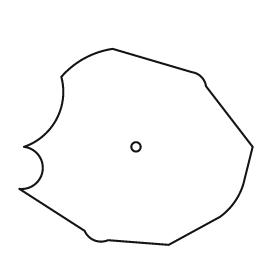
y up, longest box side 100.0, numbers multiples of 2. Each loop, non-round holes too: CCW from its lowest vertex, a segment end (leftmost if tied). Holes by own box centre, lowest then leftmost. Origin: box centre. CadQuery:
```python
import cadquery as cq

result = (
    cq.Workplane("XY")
    .moveTo(14.0, -42.0)
    .lineTo(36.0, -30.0)
    .threePointArc((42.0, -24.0), (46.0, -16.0))
    .lineTo(50.0, 0.0)
    .lineTo(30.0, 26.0)
    .threePointArc((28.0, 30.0), (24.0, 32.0))
    .lineTo(-10.0, 42.0)
    .threePointArc((-22.0, 38.0), (-32.0, 30.0))
    .threePointArc((-34.0, 12.0), (-48.0, 0.0))
    .threePointArc((-40.0, -10.0), (-50.0, -18.0))
    .lineTo(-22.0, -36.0)
    .threePointArc((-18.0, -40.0), (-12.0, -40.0))
    .close()
    .moveTo(0.0, 0.0)
    .circle(2.0)
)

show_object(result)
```